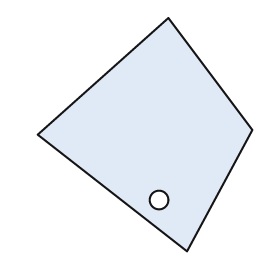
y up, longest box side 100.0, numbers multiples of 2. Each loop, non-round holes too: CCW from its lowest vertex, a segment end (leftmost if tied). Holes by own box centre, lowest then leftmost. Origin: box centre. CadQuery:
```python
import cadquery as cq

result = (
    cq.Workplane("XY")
    .moveTo(18.0, -50.0)
    .lineTo(46.0, 2.0)
    .lineTo(10.0, 50.0)
    .lineTo(-46.0, 0.0)
    .close()
    .moveTo(6.0, -28.0)
    .circle(4.0)
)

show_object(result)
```